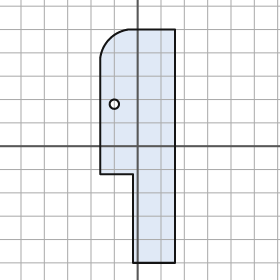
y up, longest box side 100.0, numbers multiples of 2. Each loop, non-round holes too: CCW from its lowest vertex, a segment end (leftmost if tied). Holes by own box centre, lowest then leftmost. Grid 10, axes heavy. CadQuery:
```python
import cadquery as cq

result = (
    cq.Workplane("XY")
    .moveTo(-2.0, -50.0)
    .lineTo(16.0, -50.0)
    .lineTo(16.0, 50.0)
    .lineTo(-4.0, 50.0)
    .threePointArc((-12.0, 46.0), (-16.0, 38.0))
    .lineTo(-16.0, -12.0)
    .lineTo(-2.0, -12.0)
    .close()
    .moveTo(-10.0, 18.0)
    .circle(2.0)
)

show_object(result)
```